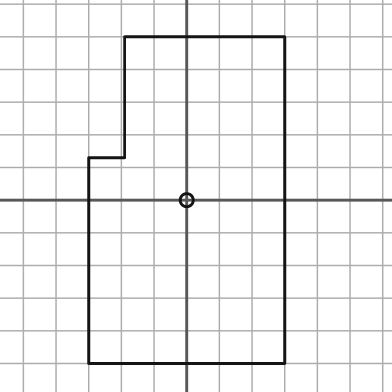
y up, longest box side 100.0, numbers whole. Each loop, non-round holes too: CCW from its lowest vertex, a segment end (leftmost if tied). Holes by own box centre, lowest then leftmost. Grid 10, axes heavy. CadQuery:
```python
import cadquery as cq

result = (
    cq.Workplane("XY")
    .moveTo(-30.0, -50.0)
    .lineTo(30.0, -50.0)
    .lineTo(30.0, 50.0)
    .lineTo(-19.0, 50.0)
    .lineTo(-19.0, 13.0)
    .lineTo(-30.0, 13.0)
    .close()
    .moveTo(0.0, 0.0)
    .circle(2.0)
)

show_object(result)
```